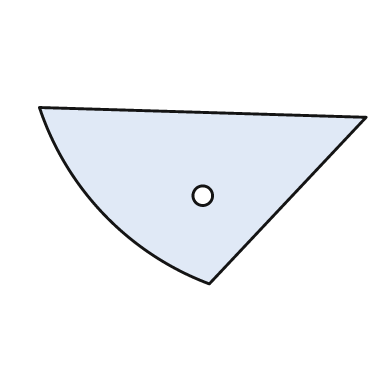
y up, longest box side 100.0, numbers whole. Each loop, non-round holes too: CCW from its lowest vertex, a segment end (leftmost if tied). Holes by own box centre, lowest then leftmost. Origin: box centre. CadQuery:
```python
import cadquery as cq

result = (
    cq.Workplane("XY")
    .moveTo(2.0, -27.0)
    .lineTo(50.0, 24.0)
    .lineTo(-50.0, 27.0)
    .threePointArc((-30.0, -6.0), (2.0, -27.0))
    .close()
    .moveTo(0.0, 0.0)
    .circle(3.0)
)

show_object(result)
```